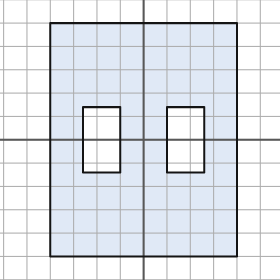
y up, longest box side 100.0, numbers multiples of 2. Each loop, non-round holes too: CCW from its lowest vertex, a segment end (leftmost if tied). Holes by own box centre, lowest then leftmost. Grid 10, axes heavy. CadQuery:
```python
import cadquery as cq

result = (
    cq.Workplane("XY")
    .moveTo(-40.0, -50.0)
    .lineTo(40.0, -50.0)
    .lineTo(40.0, 50.0)
    .lineTo(-40.0, 50.0)
    .close()
    .moveTo(-26.0, -14.0)
    .lineTo(-10.0, -14.0)
    .lineTo(-10.0, 14.0)
    .lineTo(-26.0, 14.0)
    .close()
    .moveTo(10.0, -14.0)
    .lineTo(26.0, -14.0)
    .lineTo(26.0, 14.0)
    .lineTo(10.0, 14.0)
    .close()
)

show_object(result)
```